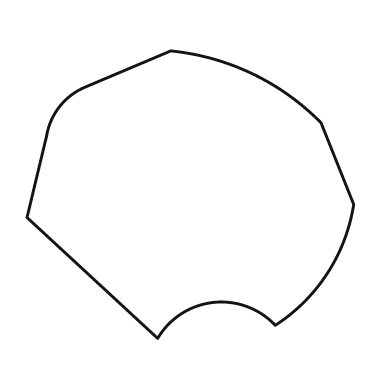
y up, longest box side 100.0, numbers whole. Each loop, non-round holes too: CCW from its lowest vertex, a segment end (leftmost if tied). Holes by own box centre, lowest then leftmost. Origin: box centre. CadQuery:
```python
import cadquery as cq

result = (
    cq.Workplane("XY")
    .moveTo(-10.0, -44.0)
    .threePointArc((7.0, -33.0), (26.0, -40.0))
    .threePointArc((42.0, -24.0), (50.0, -3.0))
    .lineTo(40.0, 22.0)
    .threePointArc((19.0, 37.0), (-6.0, 44.0))
    .lineTo(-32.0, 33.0)
    .threePointArc((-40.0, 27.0), (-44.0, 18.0))
    .lineTo(-50.0, -7.0)
    .close()
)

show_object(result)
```